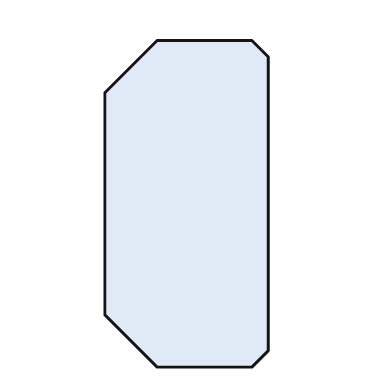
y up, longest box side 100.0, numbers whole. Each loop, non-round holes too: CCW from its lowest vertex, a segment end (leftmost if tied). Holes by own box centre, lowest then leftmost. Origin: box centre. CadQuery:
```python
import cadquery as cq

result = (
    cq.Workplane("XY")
    .moveTo(-9.0, -50.0)
    .lineTo(20.0, -50.0)
    .lineTo(25.0, -45.0)
    .lineTo(25.0, 45.0)
    .lineTo(20.0, 50.0)
    .lineTo(-9.0, 50.0)
    .lineTo(-25.0, 34.0)
    .lineTo(-25.0, -34.0)
    .close()
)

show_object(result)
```